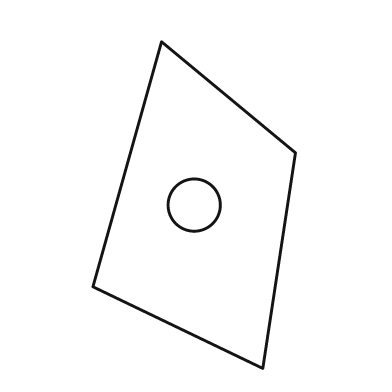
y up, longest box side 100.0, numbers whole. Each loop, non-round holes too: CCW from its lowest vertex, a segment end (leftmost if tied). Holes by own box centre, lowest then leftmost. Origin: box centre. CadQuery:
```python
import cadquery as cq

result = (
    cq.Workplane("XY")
    .moveTo(21.0, -50.0)
    .lineTo(31.0, 16.0)
    .lineTo(-10.0, 50.0)
    .lineTo(-31.0, -25.0)
    .close()
    .moveTo(0.0, 0.0)
    .circle(8.0)
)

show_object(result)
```